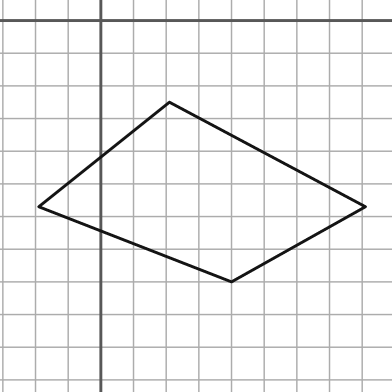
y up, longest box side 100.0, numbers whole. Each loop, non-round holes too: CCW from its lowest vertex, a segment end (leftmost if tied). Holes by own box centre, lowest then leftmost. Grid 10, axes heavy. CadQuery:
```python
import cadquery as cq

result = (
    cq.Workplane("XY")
    .moveTo(40.0, -80.0)
    .lineTo(81.0, -57.0)
    .lineTo(21.0, -25.0)
    .lineTo(-19.0, -57.0)
    .close()
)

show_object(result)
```